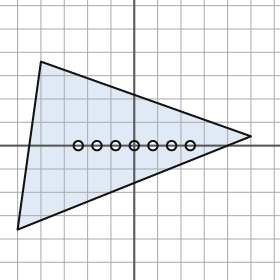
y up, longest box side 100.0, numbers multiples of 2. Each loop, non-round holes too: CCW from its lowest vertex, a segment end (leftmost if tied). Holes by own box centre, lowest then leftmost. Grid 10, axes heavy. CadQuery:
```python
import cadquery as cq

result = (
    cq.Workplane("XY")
    .moveTo(-50.0, -36.0)
    .lineTo(50.0, 4.0)
    .lineTo(-40.0, 36.0)
    .close()
    .moveTo(-24.0, 0.0)
    .circle(2.0)
    .moveTo(-16.0, 0.0)
    .circle(2.0)
    .moveTo(-8.0, 0.0)
    .circle(2.0)
    .moveTo(0.0, 0.0)
    .circle(2.0)
    .moveTo(8.0, 0.0)
    .circle(2.0)
    .moveTo(16.0, 0.0)
    .circle(2.0)
    .moveTo(24.0, 0.0)
    .circle(2.0)
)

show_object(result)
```